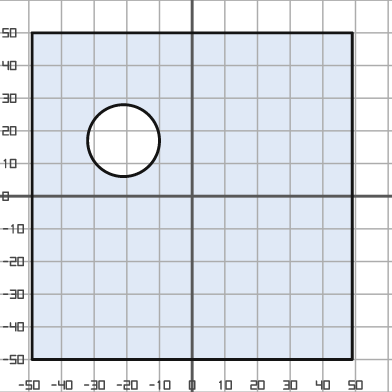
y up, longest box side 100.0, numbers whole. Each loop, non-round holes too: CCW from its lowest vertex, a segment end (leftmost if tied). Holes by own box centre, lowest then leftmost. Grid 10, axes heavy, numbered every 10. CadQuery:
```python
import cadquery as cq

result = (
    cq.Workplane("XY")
    .moveTo(-49.0, -50.0)
    .lineTo(49.0, -50.0)
    .lineTo(49.0, 50.0)
    .lineTo(-49.0, 50.0)
    .close()
    .moveTo(-21.0, 17.0)
    .circle(11.0)
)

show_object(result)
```